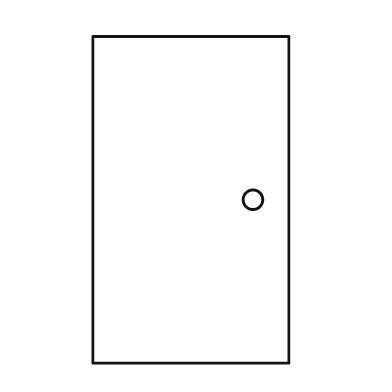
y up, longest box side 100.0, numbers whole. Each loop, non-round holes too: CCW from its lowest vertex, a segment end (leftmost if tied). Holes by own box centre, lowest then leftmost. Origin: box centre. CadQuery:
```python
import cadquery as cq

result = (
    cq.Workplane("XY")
    .moveTo(-30.0, -50.0)
    .lineTo(30.0, -50.0)
    .lineTo(30.0, 50.0)
    .lineTo(-30.0, 50.0)
    .close()
    .moveTo(19.0, 0.0)
    .circle(3.0)
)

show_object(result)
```